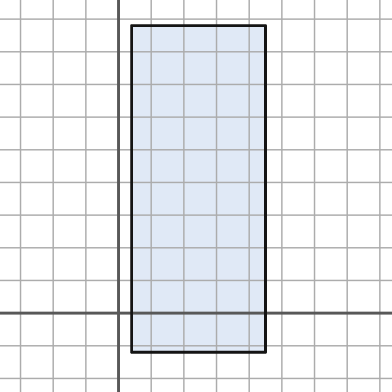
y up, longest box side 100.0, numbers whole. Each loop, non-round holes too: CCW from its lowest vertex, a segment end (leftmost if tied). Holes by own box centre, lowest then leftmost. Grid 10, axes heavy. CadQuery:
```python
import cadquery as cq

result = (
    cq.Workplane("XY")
    .moveTo(4.0, -12.0)
    .lineTo(45.0, -12.0)
    .lineTo(45.0, 88.0)
    .lineTo(4.0, 88.0)
    .close()
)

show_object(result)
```